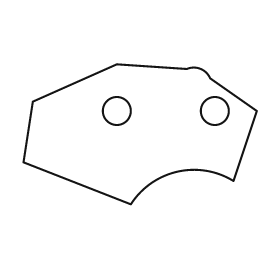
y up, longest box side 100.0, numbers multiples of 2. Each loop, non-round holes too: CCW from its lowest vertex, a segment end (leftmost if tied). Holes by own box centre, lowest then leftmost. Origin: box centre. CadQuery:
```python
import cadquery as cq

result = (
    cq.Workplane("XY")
    .moveTo(-4.0, -30.0)
    .threePointArc((16.0, -16.0), (40.0, -20.0))
    .lineTo(50.0, 10.0)
    .lineTo(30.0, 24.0)
    .threePointArc((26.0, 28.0), (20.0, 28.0))
    .lineTo(-10.0, 30.0)
    .lineTo(-46.0, 14.0)
    .lineTo(-50.0, -12.0)
    .close()
    .moveTo(-10.0, 10.0)
    .circle(6.0)
    .moveTo(32.0, 10.0)
    .circle(6.0)
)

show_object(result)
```